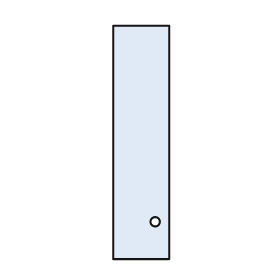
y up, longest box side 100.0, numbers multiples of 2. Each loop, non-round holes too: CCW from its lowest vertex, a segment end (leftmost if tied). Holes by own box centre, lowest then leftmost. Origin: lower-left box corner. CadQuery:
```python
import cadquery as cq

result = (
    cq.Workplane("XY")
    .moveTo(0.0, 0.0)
    .lineTo(24.0, 0.0)
    .lineTo(24.0, 100.0)
    .lineTo(0.0, 100.0)
    .close()
    .moveTo(18.0, 16.0)
    .circle(2.0)
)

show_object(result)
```